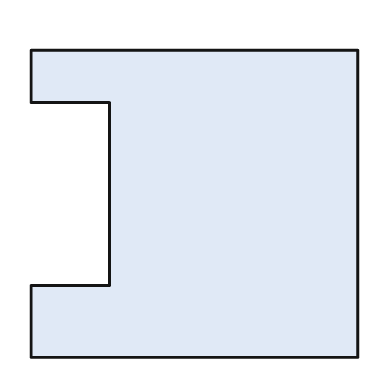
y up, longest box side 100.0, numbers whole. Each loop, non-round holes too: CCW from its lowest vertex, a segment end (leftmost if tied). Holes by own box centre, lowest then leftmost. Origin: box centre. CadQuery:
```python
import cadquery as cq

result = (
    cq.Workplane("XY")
    .moveTo(-50.0, -47.0)
    .lineTo(50.0, -47.0)
    .lineTo(50.0, 47.0)
    .lineTo(-50.0, 47.0)
    .lineTo(-50.0, 31.0)
    .lineTo(-26.0, 31.0)
    .lineTo(-26.0, -25.0)
    .lineTo(-50.0, -25.0)
    .close()
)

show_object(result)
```